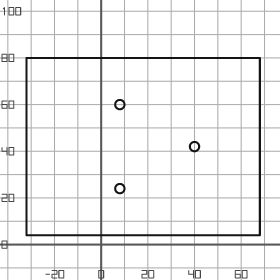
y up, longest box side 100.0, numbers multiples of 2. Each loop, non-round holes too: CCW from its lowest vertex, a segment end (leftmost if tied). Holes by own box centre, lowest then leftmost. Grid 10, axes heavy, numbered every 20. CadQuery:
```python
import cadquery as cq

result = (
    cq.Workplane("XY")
    .moveTo(-32.0, 4.0)
    .lineTo(68.0, 4.0)
    .lineTo(68.0, 80.0)
    .lineTo(-32.0, 80.0)
    .close()
    .moveTo(8.0, 24.0)
    .circle(2.0)
    .moveTo(40.0, 42.0)
    .circle(2.0)
    .moveTo(8.0, 60.0)
    .circle(2.0)
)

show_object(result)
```